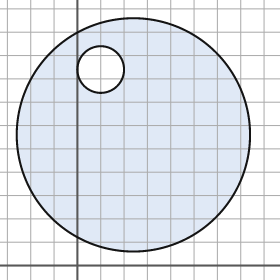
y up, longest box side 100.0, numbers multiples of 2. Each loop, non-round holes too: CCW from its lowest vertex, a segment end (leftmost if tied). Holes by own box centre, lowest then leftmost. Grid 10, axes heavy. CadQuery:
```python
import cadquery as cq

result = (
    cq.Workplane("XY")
    .moveTo(24.0, 56.0)
    .circle(50.0)
    .moveTo(10.0, 84.0)
    .circle(10.0)
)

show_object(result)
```